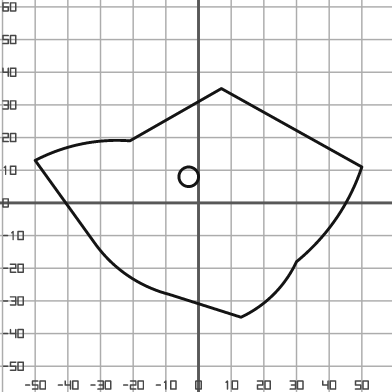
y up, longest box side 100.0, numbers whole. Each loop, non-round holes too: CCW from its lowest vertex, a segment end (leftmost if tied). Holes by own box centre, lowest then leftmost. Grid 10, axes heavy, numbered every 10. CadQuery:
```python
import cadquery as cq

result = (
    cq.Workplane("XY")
    .moveTo(13.0, -35.0)
    .threePointArc((23.0, -28.0), (30.0, -18.0))
    .threePointArc((42.0, -5.0), (50.0, 11.0))
    .lineTo(7.0, 35.0)
    .lineTo(-21.0, 19.0)
    .threePointArc((-36.0, 18.0), (-50.0, 13.0))
    .lineTo(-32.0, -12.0)
    .threePointArc((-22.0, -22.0), (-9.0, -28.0))
    .close()
    .moveTo(-3.0, 8.0)
    .circle(3.0)
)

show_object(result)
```